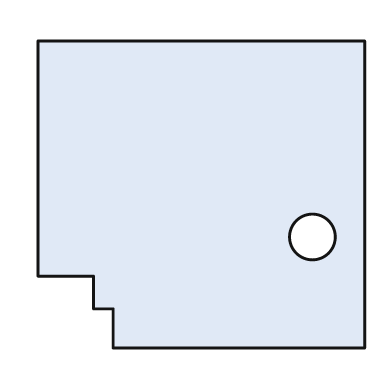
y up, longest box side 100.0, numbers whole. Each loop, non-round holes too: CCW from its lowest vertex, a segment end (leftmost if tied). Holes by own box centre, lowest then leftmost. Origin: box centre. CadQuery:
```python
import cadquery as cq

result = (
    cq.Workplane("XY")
    .moveTo(-27.0, -47.0)
    .lineTo(50.0, -47.0)
    .lineTo(50.0, 47.0)
    .lineTo(-50.0, 47.0)
    .lineTo(-50.0, -25.0)
    .lineTo(-33.0, -25.0)
    .lineTo(-33.0, -35.0)
    .lineTo(-27.0, -35.0)
    .close()
    .moveTo(34.0, -13.0)
    .circle(7.0)
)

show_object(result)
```